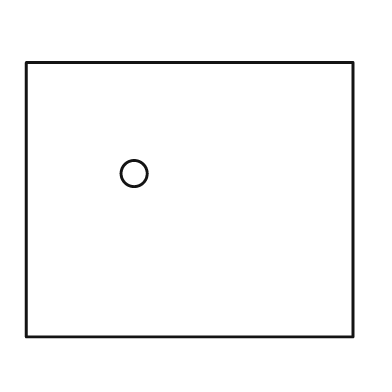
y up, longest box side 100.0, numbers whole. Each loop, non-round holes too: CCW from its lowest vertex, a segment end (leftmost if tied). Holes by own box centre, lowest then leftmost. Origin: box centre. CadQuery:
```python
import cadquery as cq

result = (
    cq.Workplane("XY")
    .moveTo(-50.0, -42.0)
    .lineTo(50.0, -42.0)
    .lineTo(50.0, 42.0)
    .lineTo(-50.0, 42.0)
    .close()
    .moveTo(-17.0, 8.0)
    .circle(4.0)
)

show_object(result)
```